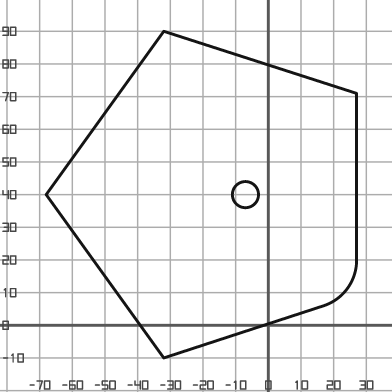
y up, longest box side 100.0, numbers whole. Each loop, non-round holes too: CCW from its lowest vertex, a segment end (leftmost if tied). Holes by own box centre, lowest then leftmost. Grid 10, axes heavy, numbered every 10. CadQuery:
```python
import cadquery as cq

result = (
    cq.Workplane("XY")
    .moveTo(-32.0, -10.0)
    .lineTo(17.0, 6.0)
    .threePointArc((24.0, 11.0), (27.0, 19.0))
    .lineTo(27.0, 71.0)
    .lineTo(-32.0, 90.0)
    .lineTo(-68.0, 40.0)
    .close()
    .moveTo(-7.0, 40.0)
    .circle(4.0)
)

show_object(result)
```